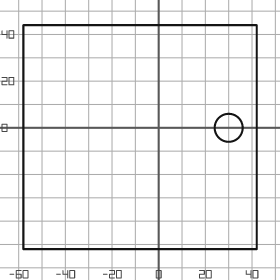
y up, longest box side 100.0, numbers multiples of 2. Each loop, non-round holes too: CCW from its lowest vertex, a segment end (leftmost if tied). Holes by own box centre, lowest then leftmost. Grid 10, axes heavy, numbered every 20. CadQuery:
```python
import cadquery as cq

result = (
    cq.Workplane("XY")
    .moveTo(-58.0, -52.0)
    .lineTo(42.0, -52.0)
    .lineTo(42.0, 44.0)
    .lineTo(-58.0, 44.0)
    .close()
    .moveTo(30.0, 0.0)
    .circle(6.0)
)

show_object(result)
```